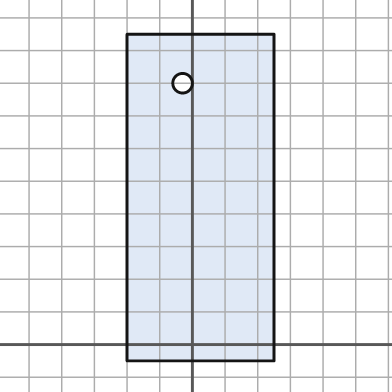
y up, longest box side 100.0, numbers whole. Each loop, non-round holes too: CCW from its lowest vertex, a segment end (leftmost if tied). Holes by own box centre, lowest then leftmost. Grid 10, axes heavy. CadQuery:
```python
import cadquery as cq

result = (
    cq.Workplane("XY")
    .moveTo(-20.0, -5.0)
    .lineTo(25.0, -5.0)
    .lineTo(25.0, 95.0)
    .lineTo(-20.0, 95.0)
    .close()
    .moveTo(-3.0, 80.0)
    .circle(3.0)
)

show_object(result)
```